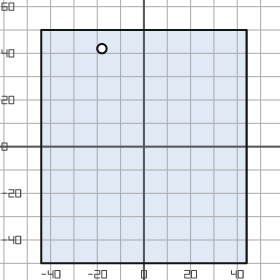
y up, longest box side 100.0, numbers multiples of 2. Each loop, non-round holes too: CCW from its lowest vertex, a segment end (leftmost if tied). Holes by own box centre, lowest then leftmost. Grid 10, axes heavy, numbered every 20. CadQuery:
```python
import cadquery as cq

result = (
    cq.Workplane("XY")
    .moveTo(-44.0, -50.0)
    .lineTo(44.0, -50.0)
    .lineTo(44.0, 50.0)
    .lineTo(-44.0, 50.0)
    .close()
    .moveTo(-18.0, 42.0)
    .circle(2.0)
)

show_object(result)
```